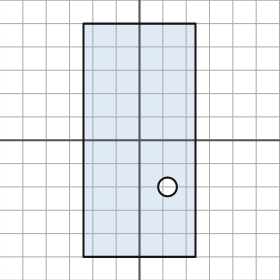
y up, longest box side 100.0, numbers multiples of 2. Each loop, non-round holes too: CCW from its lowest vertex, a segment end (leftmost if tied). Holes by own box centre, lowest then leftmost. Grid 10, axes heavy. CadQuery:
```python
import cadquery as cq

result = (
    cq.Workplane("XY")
    .moveTo(-24.0, -50.0)
    .lineTo(24.0, -50.0)
    .lineTo(24.0, 50.0)
    .lineTo(-24.0, 50.0)
    .close()
    .moveTo(12.0, -20.0)
    .circle(4.0)
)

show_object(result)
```